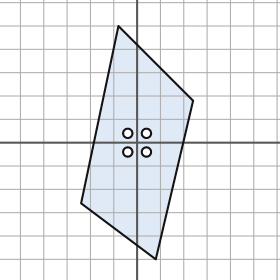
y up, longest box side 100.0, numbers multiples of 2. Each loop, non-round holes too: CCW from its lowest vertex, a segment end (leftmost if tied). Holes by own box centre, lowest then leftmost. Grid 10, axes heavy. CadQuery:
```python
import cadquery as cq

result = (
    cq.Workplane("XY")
    .moveTo(8.0, -50.0)
    .lineTo(24.0, 18.0)
    .lineTo(-8.0, 50.0)
    .lineTo(-24.0, -26.0)
    .close()
    .moveTo(-4.0, -4.0)
    .circle(2.0)
    .moveTo(4.0, -4.0)
    .circle(2.0)
    .moveTo(-4.0, 4.0)
    .circle(2.0)
    .moveTo(4.0, 4.0)
    .circle(2.0)
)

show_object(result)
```